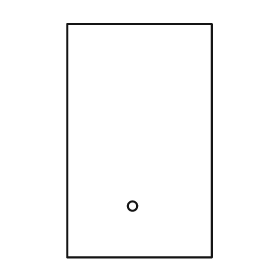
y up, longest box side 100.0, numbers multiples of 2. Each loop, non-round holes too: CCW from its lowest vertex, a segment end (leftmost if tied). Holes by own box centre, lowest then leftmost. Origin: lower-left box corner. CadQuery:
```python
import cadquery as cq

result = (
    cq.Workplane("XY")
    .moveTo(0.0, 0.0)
    .lineTo(62.0, 0.0)
    .lineTo(62.0, 100.0)
    .lineTo(0.0, 100.0)
    .close()
    .moveTo(28.0, 22.0)
    .circle(2.0)
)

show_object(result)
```